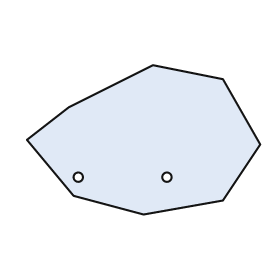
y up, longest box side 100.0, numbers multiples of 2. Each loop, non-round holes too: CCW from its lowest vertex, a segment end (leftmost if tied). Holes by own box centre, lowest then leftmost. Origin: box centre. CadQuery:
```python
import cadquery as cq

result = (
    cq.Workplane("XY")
    .moveTo(0.0, -32.0)
    .lineTo(34.0, -26.0)
    .lineTo(50.0, -2.0)
    .lineTo(34.0, 26.0)
    .lineTo(4.0, 32.0)
    .lineTo(-32.0, 14.0)
    .lineTo(-50.0, 0.0)
    .lineTo(-30.0, -24.0)
    .close()
    .moveTo(-28.0, -16.0)
    .circle(2.0)
    .moveTo(10.0, -16.0)
    .circle(2.0)
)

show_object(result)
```